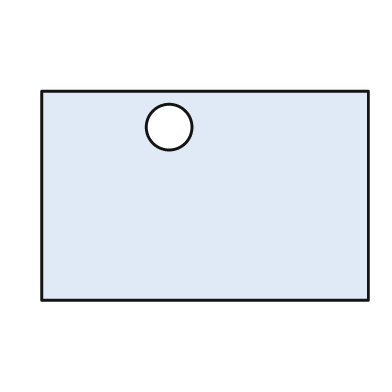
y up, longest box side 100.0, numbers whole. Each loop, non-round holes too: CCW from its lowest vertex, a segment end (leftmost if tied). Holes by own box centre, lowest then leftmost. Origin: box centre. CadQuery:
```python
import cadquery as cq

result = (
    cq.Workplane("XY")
    .moveTo(-50.0, -32.0)
    .lineTo(50.0, -32.0)
    .lineTo(50.0, 32.0)
    .lineTo(-50.0, 32.0)
    .close()
    .moveTo(-11.0, 21.0)
    .circle(7.0)
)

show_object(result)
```